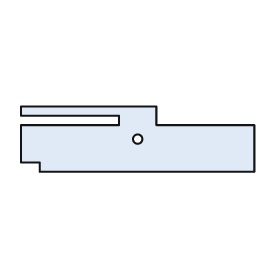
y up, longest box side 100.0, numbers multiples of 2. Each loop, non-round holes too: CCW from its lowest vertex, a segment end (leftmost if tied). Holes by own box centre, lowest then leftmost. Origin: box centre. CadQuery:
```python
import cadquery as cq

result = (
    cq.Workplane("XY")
    .moveTo(-42.0, -14.0)
    .lineTo(50.0, -14.0)
    .lineTo(50.0, 6.0)
    .lineTo(8.0, 6.0)
    .lineTo(8.0, 14.0)
    .lineTo(-50.0, 14.0)
    .lineTo(-50.0, 10.0)
    .lineTo(-8.0, 10.0)
    .lineTo(-8.0, 6.0)
    .lineTo(-50.0, 6.0)
    .lineTo(-50.0, -10.0)
    .lineTo(-42.0, -10.0)
    .close()
    .moveTo(0.0, 0.0)
    .circle(2.0)
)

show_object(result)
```